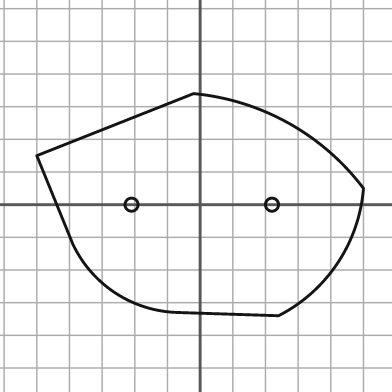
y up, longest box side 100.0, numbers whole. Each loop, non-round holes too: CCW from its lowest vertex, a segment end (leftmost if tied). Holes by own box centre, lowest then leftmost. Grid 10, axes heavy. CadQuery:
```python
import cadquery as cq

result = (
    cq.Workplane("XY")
    .moveTo(24.0, -34.0)
    .threePointArc((42.0, -18.0), (50.0, 5.0))
    .threePointArc((27.0, 25.0), (-2.0, 34.0))
    .lineTo(-50.0, 15.0)
    .lineTo(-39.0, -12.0)
    .threePointArc((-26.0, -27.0), (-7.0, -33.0))
    .close()
    .moveTo(-21.0, 0.0)
    .circle(2.0)
    .moveTo(22.0, 0.0)
    .circle(2.0)
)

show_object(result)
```